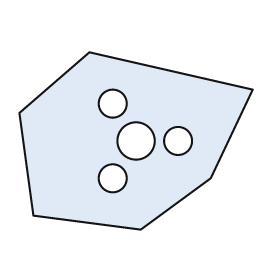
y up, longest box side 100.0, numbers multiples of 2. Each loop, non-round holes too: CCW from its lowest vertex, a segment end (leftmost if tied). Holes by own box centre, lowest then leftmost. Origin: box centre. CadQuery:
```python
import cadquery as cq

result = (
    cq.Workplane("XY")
    .moveTo(2.0, -38.0)
    .lineTo(32.0, -16.0)
    .lineTo(50.0, 22.0)
    .lineTo(-20.0, 38.0)
    .lineTo(-50.0, 12.0)
    .lineTo(-44.0, -32.0)
    .close()
    .moveTo(-10.0, -16.0)
    .circle(6.0)
    .moveTo(0.0, 0.0)
    .circle(8.0)
    .moveTo(18.0, 0.0)
    .circle(6.0)
    .moveTo(-10.0, 16.0)
    .circle(6.0)
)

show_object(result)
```